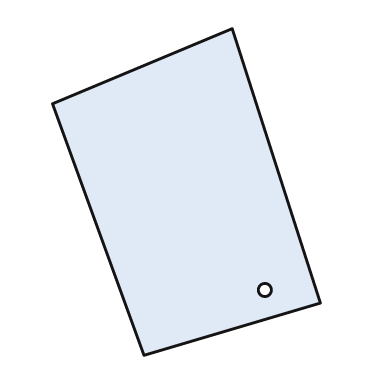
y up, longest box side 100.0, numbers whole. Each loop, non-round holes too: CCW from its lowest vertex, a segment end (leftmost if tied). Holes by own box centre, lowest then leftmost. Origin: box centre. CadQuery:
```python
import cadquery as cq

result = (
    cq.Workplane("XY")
    .moveTo(-13.0, -50.0)
    .lineTo(41.0, -34.0)
    .lineTo(14.0, 50.0)
    .lineTo(-41.0, 27.0)
    .close()
    .moveTo(24.0, -30.0)
    .circle(2.0)
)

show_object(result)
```